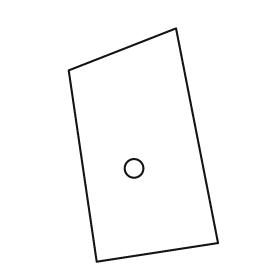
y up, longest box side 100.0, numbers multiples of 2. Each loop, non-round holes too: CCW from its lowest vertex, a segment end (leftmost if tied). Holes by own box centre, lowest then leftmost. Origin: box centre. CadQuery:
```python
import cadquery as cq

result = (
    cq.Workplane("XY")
    .moveTo(-20.0, -50.0)
    .lineTo(32.0, -42.0)
    .lineTo(14.0, 50.0)
    .lineTo(-32.0, 32.0)
    .close()
    .moveTo(-4.0, -10.0)
    .circle(4.0)
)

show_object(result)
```